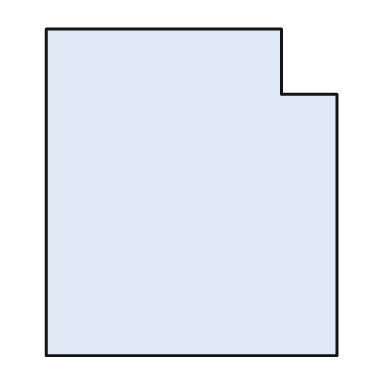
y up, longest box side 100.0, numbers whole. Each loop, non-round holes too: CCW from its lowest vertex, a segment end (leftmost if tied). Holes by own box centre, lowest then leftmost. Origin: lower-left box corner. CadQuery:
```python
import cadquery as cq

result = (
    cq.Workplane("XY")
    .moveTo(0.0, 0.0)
    .lineTo(89.0, 0.0)
    .lineTo(89.0, 80.0)
    .lineTo(72.0, 80.0)
    .lineTo(72.0, 100.0)
    .lineTo(0.0, 100.0)
    .close()
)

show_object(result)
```